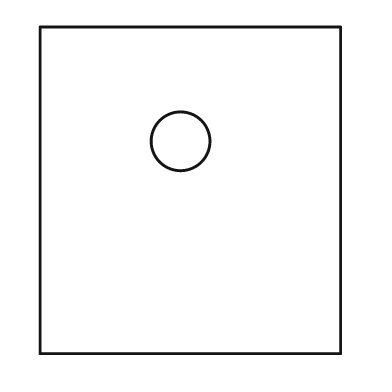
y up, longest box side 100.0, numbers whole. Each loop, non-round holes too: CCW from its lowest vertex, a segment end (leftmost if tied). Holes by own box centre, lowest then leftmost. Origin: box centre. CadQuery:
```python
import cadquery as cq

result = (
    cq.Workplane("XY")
    .moveTo(-46.0, -50.0)
    .lineTo(46.0, -50.0)
    .lineTo(46.0, 50.0)
    .lineTo(-46.0, 50.0)
    .close()
    .moveTo(-3.0, 15.0)
    .circle(9.0)
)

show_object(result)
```